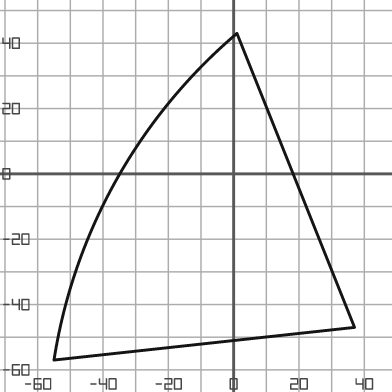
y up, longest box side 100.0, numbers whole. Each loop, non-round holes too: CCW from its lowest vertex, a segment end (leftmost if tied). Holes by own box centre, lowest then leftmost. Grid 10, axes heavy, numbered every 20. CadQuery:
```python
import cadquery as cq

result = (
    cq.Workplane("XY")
    .moveTo(-55.0, -57.0)
    .lineTo(37.0, -47.0)
    .lineTo(1.0, 43.0)
    .threePointArc((-36.0, -2.0), (-55.0, -57.0))
    .close()
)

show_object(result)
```